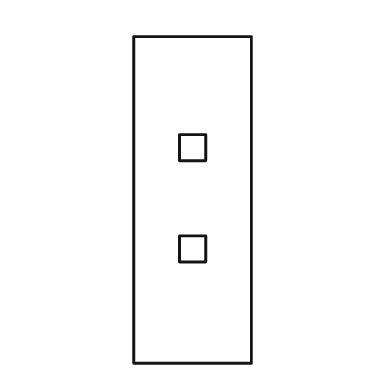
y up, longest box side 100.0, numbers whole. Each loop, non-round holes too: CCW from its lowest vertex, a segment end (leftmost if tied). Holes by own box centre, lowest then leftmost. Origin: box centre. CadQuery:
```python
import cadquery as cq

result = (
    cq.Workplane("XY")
    .moveTo(-18.0, -50.0)
    .lineTo(18.0, -50.0)
    .lineTo(18.0, 50.0)
    .lineTo(-18.0, 50.0)
    .close()
    .moveTo(-4.0, -19.0)
    .lineTo(4.0, -19.0)
    .lineTo(4.0, -11.0)
    .lineTo(-4.0, -11.0)
    .close()
    .moveTo(-4.0, 12.0)
    .lineTo(4.0, 12.0)
    .lineTo(4.0, 20.0)
    .lineTo(-4.0, 20.0)
    .close()
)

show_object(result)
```